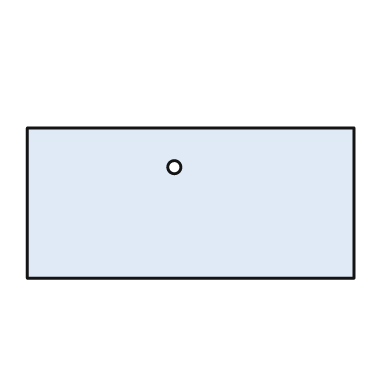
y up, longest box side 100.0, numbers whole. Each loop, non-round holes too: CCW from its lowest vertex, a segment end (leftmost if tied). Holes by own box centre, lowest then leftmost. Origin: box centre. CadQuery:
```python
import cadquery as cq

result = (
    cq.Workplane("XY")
    .moveTo(-50.0, -23.0)
    .lineTo(50.0, -23.0)
    .lineTo(50.0, 23.0)
    .lineTo(-50.0, 23.0)
    .close()
    .moveTo(-5.0, 11.0)
    .circle(2.0)
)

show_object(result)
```